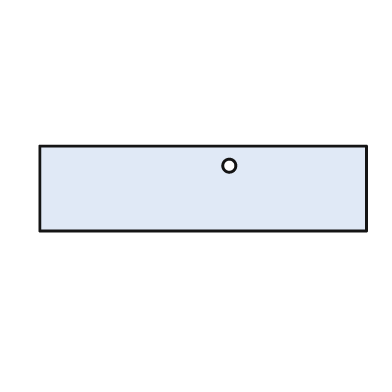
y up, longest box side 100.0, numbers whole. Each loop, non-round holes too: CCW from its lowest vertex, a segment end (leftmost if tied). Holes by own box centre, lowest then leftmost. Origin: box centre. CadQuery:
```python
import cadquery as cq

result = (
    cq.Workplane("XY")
    .moveTo(-50.0, -13.0)
    .lineTo(50.0, -13.0)
    .lineTo(50.0, 13.0)
    .lineTo(-50.0, 13.0)
    .close()
    .moveTo(8.0, 7.0)
    .circle(2.0)
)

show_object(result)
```